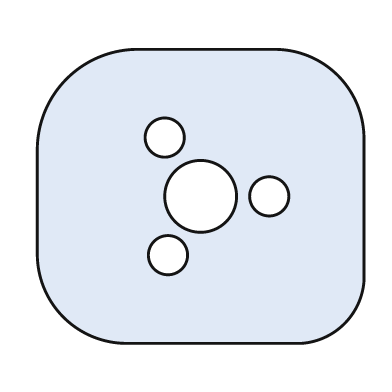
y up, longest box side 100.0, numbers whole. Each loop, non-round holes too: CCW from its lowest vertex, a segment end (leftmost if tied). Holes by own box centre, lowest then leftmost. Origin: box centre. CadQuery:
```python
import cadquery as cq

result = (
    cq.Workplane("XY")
    .moveTo(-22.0, -45.0)
    .lineTo(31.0, -45.0)
    .threePointArc((44.0, -39.0), (50.0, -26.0))
    .lineTo(50.0, 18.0)
    .threePointArc((42.0, 37.0), (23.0, 45.0))
    .lineTo(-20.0, 45.0)
    .threePointArc((-41.0, 36.0), (-50.0, 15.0))
    .lineTo(-50.0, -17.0)
    .threePointArc((-42.0, -37.0), (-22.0, -45.0))
    .close()
    .moveTo(-10.0, -18.0)
    .circle(6.0)
    .moveTo(0.0, 0.0)
    .circle(11.0)
    .moveTo(21.0, 0.0)
    .circle(6.0)
    .moveTo(-11.0, 18.0)
    .circle(6.0)
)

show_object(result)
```